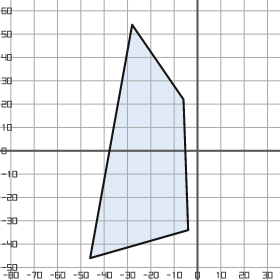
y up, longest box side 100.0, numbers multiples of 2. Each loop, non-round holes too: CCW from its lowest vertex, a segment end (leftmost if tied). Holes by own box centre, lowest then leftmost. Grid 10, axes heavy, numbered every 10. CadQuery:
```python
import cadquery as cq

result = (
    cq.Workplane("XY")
    .moveTo(-46.0, -46.0)
    .lineTo(-4.0, -34.0)
    .lineTo(-6.0, 22.0)
    .lineTo(-28.0, 54.0)
    .close()
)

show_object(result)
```